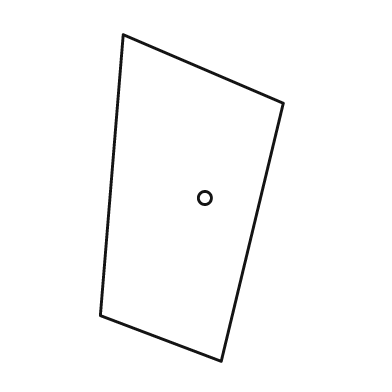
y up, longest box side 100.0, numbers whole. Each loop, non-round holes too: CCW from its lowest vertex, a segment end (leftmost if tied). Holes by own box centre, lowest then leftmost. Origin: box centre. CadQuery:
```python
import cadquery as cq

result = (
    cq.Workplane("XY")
    .moveTo(9.0, -50.0)
    .lineTo(28.0, 29.0)
    .lineTo(-21.0, 50.0)
    .lineTo(-28.0, -36.0)
    .close()
    .moveTo(4.0, 0.0)
    .circle(2.0)
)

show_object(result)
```